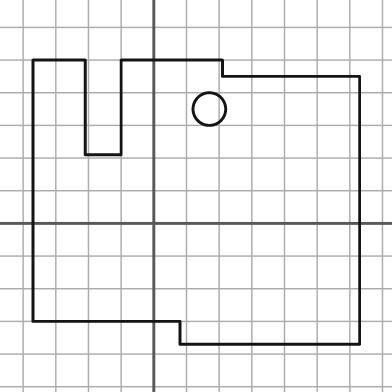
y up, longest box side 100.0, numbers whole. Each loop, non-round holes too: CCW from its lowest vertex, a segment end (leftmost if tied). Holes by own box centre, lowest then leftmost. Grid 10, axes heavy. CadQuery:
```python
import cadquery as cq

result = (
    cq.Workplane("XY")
    .moveTo(8.0, -37.0)
    .lineTo(63.0, -37.0)
    .lineTo(63.0, 45.0)
    .lineTo(21.0, 45.0)
    .lineTo(21.0, 50.0)
    .lineTo(-10.0, 50.0)
    .lineTo(-10.0, 21.0)
    .lineTo(-21.0, 21.0)
    .lineTo(-21.0, 50.0)
    .lineTo(-37.0, 50.0)
    .lineTo(-37.0, -30.0)
    .lineTo(8.0, -30.0)
    .close()
    .moveTo(17.0, 35.0)
    .circle(5.0)
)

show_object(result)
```